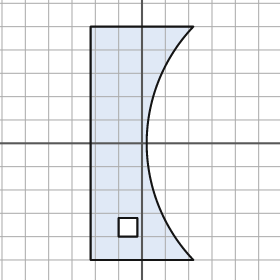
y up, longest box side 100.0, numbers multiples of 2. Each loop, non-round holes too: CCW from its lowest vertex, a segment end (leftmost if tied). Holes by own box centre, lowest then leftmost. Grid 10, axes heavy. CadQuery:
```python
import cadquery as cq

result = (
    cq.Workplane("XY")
    .moveTo(-22.0, -50.0)
    .lineTo(22.0, -50.0)
    .threePointArc((2.0, 0.0), (22.0, 50.0))
    .lineTo(-22.0, 50.0)
    .close()
    .moveTo(-10.0, -40.0)
    .lineTo(-2.0, -40.0)
    .lineTo(-2.0, -32.0)
    .lineTo(-10.0, -32.0)
    .close()
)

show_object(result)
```